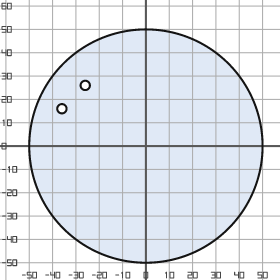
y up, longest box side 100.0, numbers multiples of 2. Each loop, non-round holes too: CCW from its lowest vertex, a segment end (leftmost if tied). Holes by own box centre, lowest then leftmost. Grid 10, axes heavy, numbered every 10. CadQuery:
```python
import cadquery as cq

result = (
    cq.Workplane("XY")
    .moveTo(0.0, 0.0)
    .circle(50.0)
    .moveTo(-36.0, 16.0)
    .circle(2.0)
    .moveTo(-26.0, 26.0)
    .circle(2.0)
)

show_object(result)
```